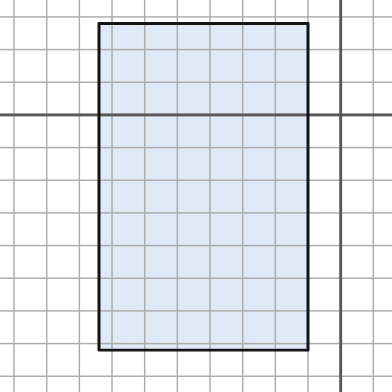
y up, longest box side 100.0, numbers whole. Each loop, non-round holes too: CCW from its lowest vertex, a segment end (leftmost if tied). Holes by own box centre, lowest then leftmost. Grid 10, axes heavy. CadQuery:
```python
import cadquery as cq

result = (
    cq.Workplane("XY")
    .moveTo(-74.0, -72.0)
    .lineTo(-10.0, -72.0)
    .lineTo(-10.0, 28.0)
    .lineTo(-74.0, 28.0)
    .close()
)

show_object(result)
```